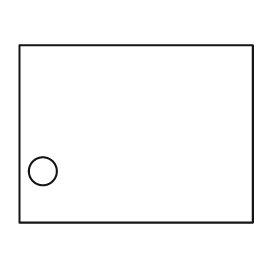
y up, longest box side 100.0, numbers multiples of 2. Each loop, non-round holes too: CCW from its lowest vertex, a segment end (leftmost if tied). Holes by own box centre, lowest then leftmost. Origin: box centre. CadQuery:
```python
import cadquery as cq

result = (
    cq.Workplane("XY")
    .moveTo(-50.0, -38.0)
    .lineTo(50.0, -38.0)
    .lineTo(50.0, 38.0)
    .lineTo(-50.0, 38.0)
    .close()
    .moveTo(-40.0, -16.0)
    .circle(6.0)
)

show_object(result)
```